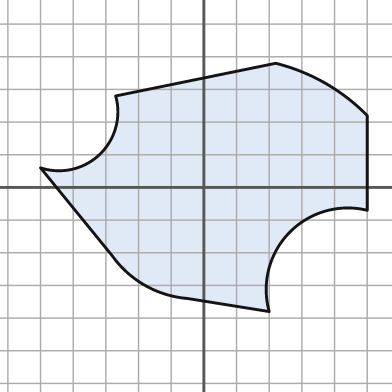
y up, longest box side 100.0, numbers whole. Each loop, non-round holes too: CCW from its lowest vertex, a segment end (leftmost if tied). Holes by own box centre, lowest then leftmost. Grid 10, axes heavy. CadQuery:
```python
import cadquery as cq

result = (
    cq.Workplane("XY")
    .moveTo(20.0, -38.0)
    .threePointArc((26.0, -14.0), (50.0, -7.0))
    .lineTo(50.0, 22.0)
    .threePointArc((37.0, 32.0), (22.0, 38.0))
    .lineTo(-27.0, 28.0)
    .threePointArc((-32.0, 10.0), (-50.0, 6.0))
    .lineTo(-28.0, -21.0)
    .threePointArc((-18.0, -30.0), (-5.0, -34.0))
    .close()
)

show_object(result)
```